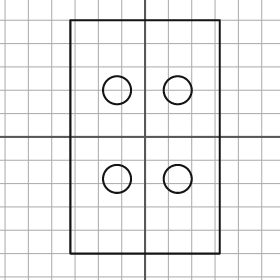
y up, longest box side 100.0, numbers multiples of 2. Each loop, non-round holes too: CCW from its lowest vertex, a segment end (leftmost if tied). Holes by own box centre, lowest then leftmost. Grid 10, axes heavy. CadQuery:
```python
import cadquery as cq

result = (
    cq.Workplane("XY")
    .moveTo(-32.0, -50.0)
    .lineTo(32.0, -50.0)
    .lineTo(32.0, 50.0)
    .lineTo(-32.0, 50.0)
    .close()
    .moveTo(-12.0, -18.0)
    .circle(6.0)
    .moveTo(14.0, -18.0)
    .circle(6.0)
    .moveTo(-12.0, 20.0)
    .circle(6.0)
    .moveTo(14.0, 20.0)
    .circle(6.0)
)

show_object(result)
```